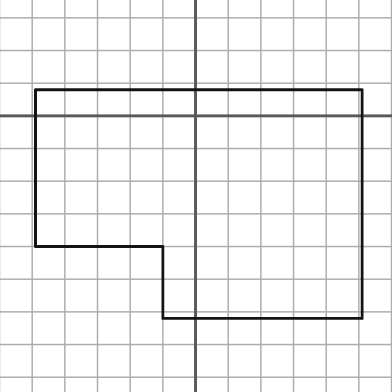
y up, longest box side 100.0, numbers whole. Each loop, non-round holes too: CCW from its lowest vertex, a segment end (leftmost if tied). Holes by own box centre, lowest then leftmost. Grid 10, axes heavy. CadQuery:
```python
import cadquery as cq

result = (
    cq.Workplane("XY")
    .moveTo(-10.0, -62.0)
    .lineTo(51.0, -62.0)
    .lineTo(51.0, 8.0)
    .lineTo(-49.0, 8.0)
    .lineTo(-49.0, -40.0)
    .lineTo(-10.0, -40.0)
    .close()
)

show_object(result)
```